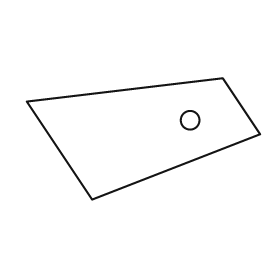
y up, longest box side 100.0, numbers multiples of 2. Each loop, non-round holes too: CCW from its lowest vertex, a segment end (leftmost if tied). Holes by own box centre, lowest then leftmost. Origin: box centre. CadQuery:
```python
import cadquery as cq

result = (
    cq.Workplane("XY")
    .moveTo(-22.0, -26.0)
    .lineTo(50.0, 2.0)
    .lineTo(34.0, 26.0)
    .lineTo(-50.0, 16.0)
    .close()
    .moveTo(20.0, 8.0)
    .circle(4.0)
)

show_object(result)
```